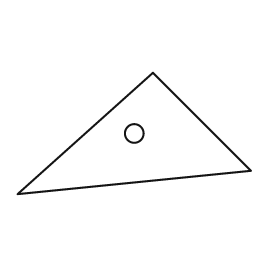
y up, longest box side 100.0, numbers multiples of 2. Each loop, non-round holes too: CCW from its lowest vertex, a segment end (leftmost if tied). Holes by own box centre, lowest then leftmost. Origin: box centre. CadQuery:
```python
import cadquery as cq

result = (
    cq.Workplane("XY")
    .moveTo(-50.0, -26.0)
    .lineTo(50.0, -16.0)
    .lineTo(8.0, 26.0)
    .close()
    .moveTo(0.0, 0.0)
    .circle(4.0)
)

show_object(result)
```